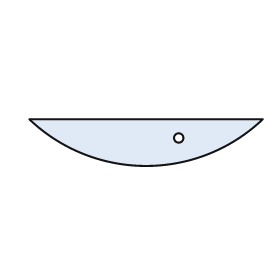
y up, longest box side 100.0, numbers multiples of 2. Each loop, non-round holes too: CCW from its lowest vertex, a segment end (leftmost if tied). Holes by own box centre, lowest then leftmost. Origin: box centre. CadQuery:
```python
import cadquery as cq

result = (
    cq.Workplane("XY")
    .moveTo(-50.0, 10.0)
    .threePointArc((0.0, -10.0), (50.0, 10.0))
    .close()
    .moveTo(14.0, 2.0)
    .circle(2.0)
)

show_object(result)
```